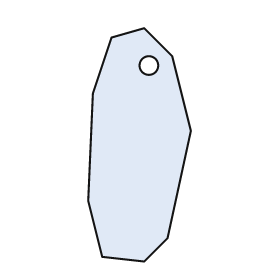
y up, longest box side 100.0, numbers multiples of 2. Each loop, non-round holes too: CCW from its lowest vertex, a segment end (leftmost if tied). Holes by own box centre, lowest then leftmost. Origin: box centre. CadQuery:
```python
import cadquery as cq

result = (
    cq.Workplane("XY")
    .moveTo(2.0, -50.0)
    .lineTo(12.0, -40.0)
    .lineTo(22.0, 6.0)
    .lineTo(14.0, 38.0)
    .lineTo(2.0, 50.0)
    .lineTo(-12.0, 46.0)
    .lineTo(-20.0, 22.0)
    .lineTo(-22.0, -24.0)
    .lineTo(-16.0, -48.0)
    .close()
    .moveTo(4.0, 34.0)
    .circle(4.0)
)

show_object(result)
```